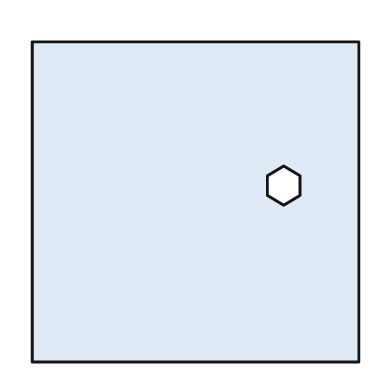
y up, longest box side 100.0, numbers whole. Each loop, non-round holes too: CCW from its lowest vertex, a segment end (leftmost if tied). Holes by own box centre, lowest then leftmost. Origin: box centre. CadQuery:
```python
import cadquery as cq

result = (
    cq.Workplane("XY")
    .moveTo(-50.0, -49.0)
    .lineTo(50.0, -49.0)
    .lineTo(50.0, 49.0)
    .lineTo(-50.0, 49.0)
    .close()
    .moveTo(27.0, -1.0)
    .lineTo(32.0, 2.0)
    .lineTo(32.0, 8.0)
    .lineTo(27.0, 11.0)
    .lineTo(22.0, 8.0)
    .lineTo(22.0, 2.0)
    .close()
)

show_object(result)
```